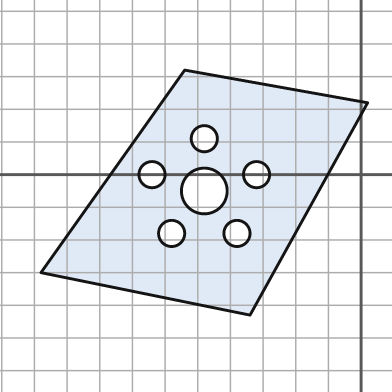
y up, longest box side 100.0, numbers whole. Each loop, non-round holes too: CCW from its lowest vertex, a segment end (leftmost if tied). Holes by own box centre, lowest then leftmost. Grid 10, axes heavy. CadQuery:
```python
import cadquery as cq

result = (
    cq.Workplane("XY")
    .moveTo(-34.0, -43.0)
    .lineTo(2.0, 22.0)
    .lineTo(-54.0, 32.0)
    .lineTo(-98.0, -30.0)
    .close()
    .moveTo(-58.0, -18.0)
    .circle(4.0)
    .moveTo(-38.0, -18.0)
    .circle(4.0)
    .moveTo(-48.0, -5.0)
    .circle(7.0)
    .moveTo(-64.0, 0.0)
    .circle(4.0)
    .moveTo(-32.0, 0.0)
    .circle(4.0)
    .moveTo(-48.0, 11.0)
    .circle(4.0)
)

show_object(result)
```